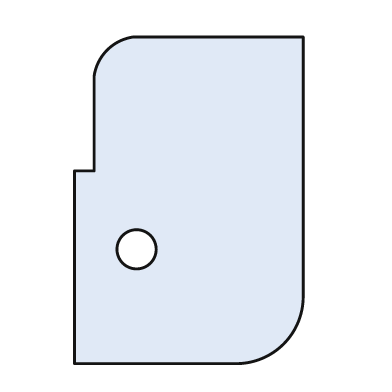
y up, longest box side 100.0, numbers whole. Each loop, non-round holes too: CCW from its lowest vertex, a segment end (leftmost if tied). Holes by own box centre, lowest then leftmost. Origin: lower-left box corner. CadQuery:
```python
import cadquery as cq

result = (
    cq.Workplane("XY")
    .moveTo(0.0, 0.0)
    .lineTo(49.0, 0.0)
    .threePointArc((64.0, 6.0), (70.0, 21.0))
    .lineTo(70.0, 100.0)
    .lineTo(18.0, 100.0)
    .threePointArc((10.0, 96.0), (6.0, 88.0))
    .lineTo(6.0, 59.0)
    .lineTo(0.0, 59.0)
    .close()
    .moveTo(19.0, 35.0)
    .circle(6.0)
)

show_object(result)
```